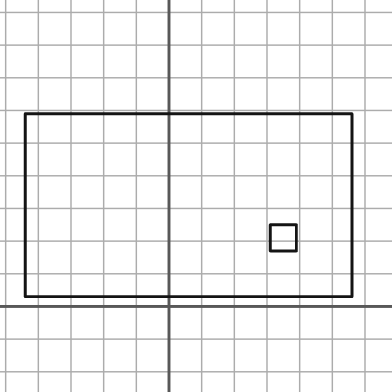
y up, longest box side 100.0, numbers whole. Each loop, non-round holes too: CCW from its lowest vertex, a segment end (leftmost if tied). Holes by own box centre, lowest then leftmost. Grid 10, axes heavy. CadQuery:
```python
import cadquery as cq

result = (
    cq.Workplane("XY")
    .moveTo(-44.0, 3.0)
    .lineTo(56.0, 3.0)
    .lineTo(56.0, 59.0)
    .lineTo(-44.0, 59.0)
    .close()
    .moveTo(31.0, 17.0)
    .lineTo(39.0, 17.0)
    .lineTo(39.0, 25.0)
    .lineTo(31.0, 25.0)
    .close()
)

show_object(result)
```